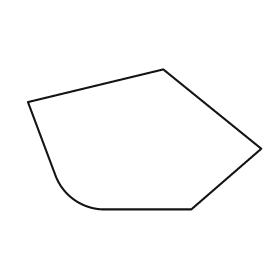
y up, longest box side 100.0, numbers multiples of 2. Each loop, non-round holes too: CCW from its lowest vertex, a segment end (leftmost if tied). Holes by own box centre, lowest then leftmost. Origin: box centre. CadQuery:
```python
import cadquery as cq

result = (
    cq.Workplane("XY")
    .moveTo(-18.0, -30.0)
    .lineTo(20.0, -30.0)
    .lineTo(50.0, -4.0)
    .lineTo(8.0, 30.0)
    .lineTo(-50.0, 16.0)
    .lineTo(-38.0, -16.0)
    .threePointArc((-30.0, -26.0), (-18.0, -30.0))
    .close()
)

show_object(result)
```